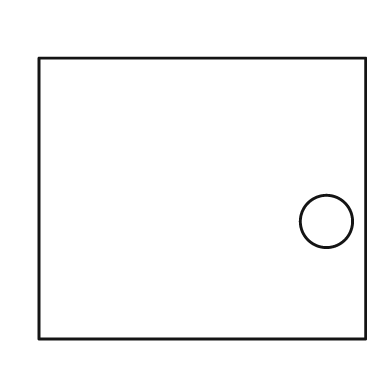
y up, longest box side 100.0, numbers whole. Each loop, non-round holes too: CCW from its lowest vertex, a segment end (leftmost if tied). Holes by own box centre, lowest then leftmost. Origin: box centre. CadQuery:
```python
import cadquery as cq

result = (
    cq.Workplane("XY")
    .moveTo(-50.0, -43.0)
    .lineTo(50.0, -43.0)
    .lineTo(50.0, 43.0)
    .lineTo(-50.0, 43.0)
    .close()
    .moveTo(38.0, -7.0)
    .circle(8.0)
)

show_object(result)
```